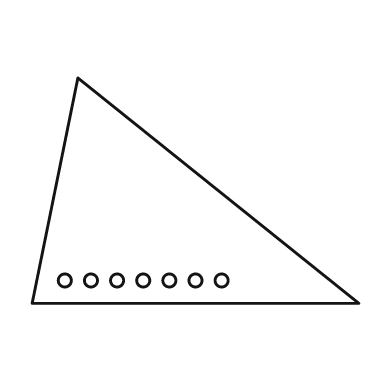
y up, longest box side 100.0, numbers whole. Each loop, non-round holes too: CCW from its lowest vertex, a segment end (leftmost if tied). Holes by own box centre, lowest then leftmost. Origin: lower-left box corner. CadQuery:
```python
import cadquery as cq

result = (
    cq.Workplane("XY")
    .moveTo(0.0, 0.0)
    .lineTo(100.0, 0.0)
    .lineTo(14.0, 69.0)
    .close()
    .moveTo(10.0, 7.0)
    .circle(2.0)
    .moveTo(18.0, 7.0)
    .circle(2.0)
    .moveTo(26.0, 7.0)
    .circle(2.0)
    .moveTo(34.0, 7.0)
    .circle(2.0)
    .moveTo(42.0, 7.0)
    .circle(2.0)
    .moveTo(50.0, 7.0)
    .circle(2.0)
    .moveTo(58.0, 7.0)
    .circle(2.0)
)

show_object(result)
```